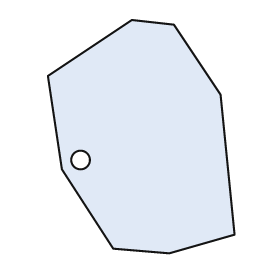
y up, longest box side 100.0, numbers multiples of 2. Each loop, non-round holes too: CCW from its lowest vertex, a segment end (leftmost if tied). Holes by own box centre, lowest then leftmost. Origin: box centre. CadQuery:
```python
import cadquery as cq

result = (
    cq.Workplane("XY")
    .moveTo(12.0, -50.0)
    .lineTo(40.0, -42.0)
    .lineTo(34.0, 18.0)
    .lineTo(14.0, 48.0)
    .lineTo(-4.0, 50.0)
    .lineTo(-40.0, 26.0)
    .lineTo(-34.0, -14.0)
    .lineTo(-12.0, -48.0)
    .close()
    .moveTo(-26.0, -10.0)
    .circle(4.0)
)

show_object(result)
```